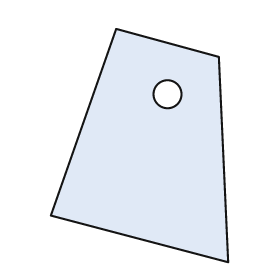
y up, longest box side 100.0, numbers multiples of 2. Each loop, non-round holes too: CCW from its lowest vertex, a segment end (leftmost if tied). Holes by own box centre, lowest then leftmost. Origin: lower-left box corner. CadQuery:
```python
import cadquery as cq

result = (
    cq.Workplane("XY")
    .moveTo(76.0, 0.0)
    .lineTo(72.0, 88.0)
    .lineTo(28.0, 100.0)
    .lineTo(0.0, 20.0)
    .close()
    .moveTo(50.0, 72.0)
    .circle(6.0)
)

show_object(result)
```